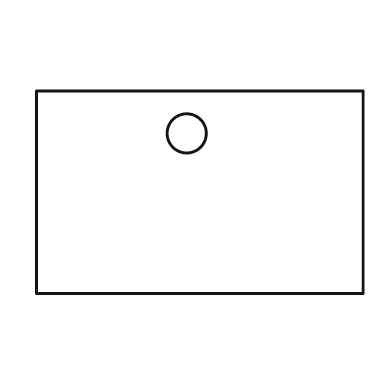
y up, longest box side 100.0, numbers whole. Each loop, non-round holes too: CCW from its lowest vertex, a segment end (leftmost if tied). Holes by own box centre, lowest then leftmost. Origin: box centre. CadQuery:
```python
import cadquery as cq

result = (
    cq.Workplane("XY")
    .moveTo(-50.0, -31.0)
    .lineTo(50.0, -31.0)
    .lineTo(50.0, 31.0)
    .lineTo(-50.0, 31.0)
    .close()
    .moveTo(-4.0, 18.0)
    .circle(6.0)
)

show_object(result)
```